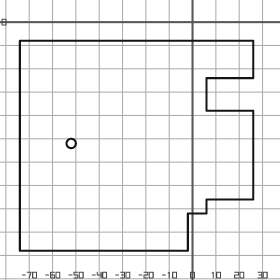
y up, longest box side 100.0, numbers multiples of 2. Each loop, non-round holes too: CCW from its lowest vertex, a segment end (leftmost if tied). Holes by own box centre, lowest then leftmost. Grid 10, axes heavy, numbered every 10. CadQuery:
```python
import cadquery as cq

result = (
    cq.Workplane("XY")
    .moveTo(-74.0, -98.0)
    .lineTo(-2.0, -98.0)
    .lineTo(-2.0, -82.0)
    .lineTo(6.0, -82.0)
    .lineTo(6.0, -76.0)
    .lineTo(26.0, -76.0)
    .lineTo(26.0, -38.0)
    .lineTo(6.0, -38.0)
    .lineTo(6.0, -24.0)
    .lineTo(26.0, -24.0)
    .lineTo(26.0, -8.0)
    .lineTo(-74.0, -8.0)
    .close()
    .moveTo(-52.0, -52.0)
    .circle(2.0)
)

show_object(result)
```